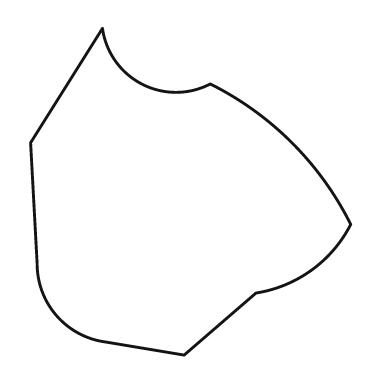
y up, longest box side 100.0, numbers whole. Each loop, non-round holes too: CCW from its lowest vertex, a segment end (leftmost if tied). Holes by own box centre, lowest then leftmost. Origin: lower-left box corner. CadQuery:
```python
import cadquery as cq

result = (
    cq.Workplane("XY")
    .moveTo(47.0, 0.0)
    .lineTo(69.0, 19.0)
    .threePointArc((86.0, 26.0), (98.0, 40.0))
    .threePointArc((80.0, 65.0), (55.0, 83.0))
    .threePointArc((34.0, 83.0), (22.0, 100.0))
    .lineTo(0.0, 65.0)
    .lineTo(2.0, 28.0)
    .threePointArc((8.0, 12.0), (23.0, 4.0))
    .close()
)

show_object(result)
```